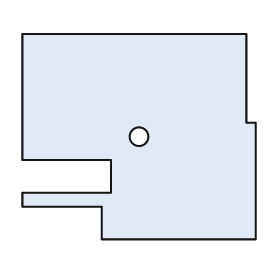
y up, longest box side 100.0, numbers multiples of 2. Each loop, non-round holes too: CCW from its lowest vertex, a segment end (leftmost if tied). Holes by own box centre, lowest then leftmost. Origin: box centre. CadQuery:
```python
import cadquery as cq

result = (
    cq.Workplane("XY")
    .moveTo(-16.0, -44.0)
    .lineTo(50.0, -44.0)
    .lineTo(50.0, 6.0)
    .lineTo(46.0, 6.0)
    .lineTo(46.0, 44.0)
    .lineTo(-50.0, 44.0)
    .lineTo(-50.0, -10.0)
    .lineTo(-12.0, -10.0)
    .lineTo(-12.0, -24.0)
    .lineTo(-50.0, -24.0)
    .lineTo(-50.0, -30.0)
    .lineTo(-16.0, -30.0)
    .close()
    .moveTo(0.0, 0.0)
    .circle(4.0)
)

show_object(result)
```